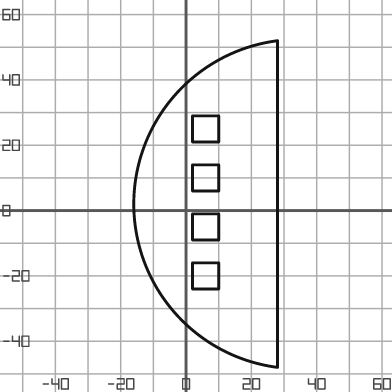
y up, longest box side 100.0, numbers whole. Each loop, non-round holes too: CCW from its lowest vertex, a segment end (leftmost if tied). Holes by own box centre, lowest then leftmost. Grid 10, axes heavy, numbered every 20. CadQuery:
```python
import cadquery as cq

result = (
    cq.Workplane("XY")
    .moveTo(28.0, -48.0)
    .lineTo(28.0, 52.0)
    .threePointArc((-16.0, 2.0), (28.0, -48.0))
    .close()
    .moveTo(2.0, -24.0)
    .lineTo(10.0, -24.0)
    .lineTo(10.0, -16.0)
    .lineTo(2.0, -16.0)
    .close()
    .moveTo(2.0, -9.0)
    .lineTo(10.0, -9.0)
    .lineTo(10.0, -1.0)
    .lineTo(2.0, -1.0)
    .close()
    .moveTo(2.0, 6.0)
    .lineTo(10.0, 6.0)
    .lineTo(10.0, 14.0)
    .lineTo(2.0, 14.0)
    .close()
    .moveTo(2.0, 21.0)
    .lineTo(10.0, 21.0)
    .lineTo(10.0, 29.0)
    .lineTo(2.0, 29.0)
    .close()
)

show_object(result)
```